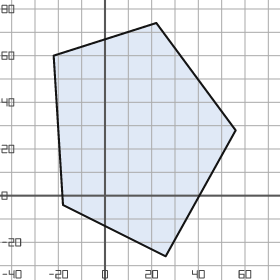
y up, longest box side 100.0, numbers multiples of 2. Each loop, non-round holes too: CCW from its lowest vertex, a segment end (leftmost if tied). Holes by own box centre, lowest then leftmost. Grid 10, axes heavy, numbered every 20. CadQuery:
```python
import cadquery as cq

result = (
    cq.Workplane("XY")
    .moveTo(26.0, -26.0)
    .lineTo(56.0, 28.0)
    .lineTo(22.0, 74.0)
    .lineTo(-22.0, 60.0)
    .lineTo(-18.0, -4.0)
    .close()
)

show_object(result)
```